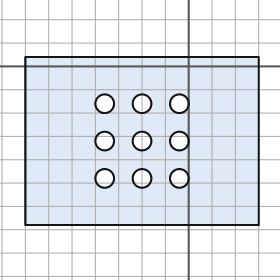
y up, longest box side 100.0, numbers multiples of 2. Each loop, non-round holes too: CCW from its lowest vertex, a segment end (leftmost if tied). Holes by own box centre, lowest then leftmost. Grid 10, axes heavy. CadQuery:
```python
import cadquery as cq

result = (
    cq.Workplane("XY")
    .moveTo(-70.0, -68.0)
    .lineTo(30.0, -68.0)
    .lineTo(30.0, 4.0)
    .lineTo(-70.0, 4.0)
    .close()
    .moveTo(-36.0, -48.0)
    .circle(4.0)
    .moveTo(-20.0, -48.0)
    .circle(4.0)
    .moveTo(-4.0, -48.0)
    .circle(4.0)
    .moveTo(-36.0, -32.0)
    .circle(4.0)
    .moveTo(-20.0, -32.0)
    .circle(4.0)
    .moveTo(-4.0, -32.0)
    .circle(4.0)
    .moveTo(-36.0, -16.0)
    .circle(4.0)
    .moveTo(-20.0, -16.0)
    .circle(4.0)
    .moveTo(-4.0, -16.0)
    .circle(4.0)
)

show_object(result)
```